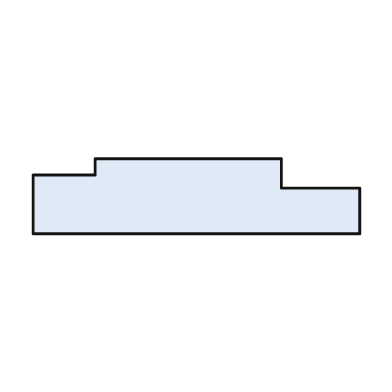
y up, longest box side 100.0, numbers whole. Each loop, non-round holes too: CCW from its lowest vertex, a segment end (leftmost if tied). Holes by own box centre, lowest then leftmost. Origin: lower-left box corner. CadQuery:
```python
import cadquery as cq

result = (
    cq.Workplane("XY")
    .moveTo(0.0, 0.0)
    .lineTo(100.0, 0.0)
    .lineTo(100.0, 14.0)
    .lineTo(76.0, 14.0)
    .lineTo(76.0, 23.0)
    .lineTo(19.0, 23.0)
    .lineTo(19.0, 18.0)
    .lineTo(0.0, 18.0)
    .close()
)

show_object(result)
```